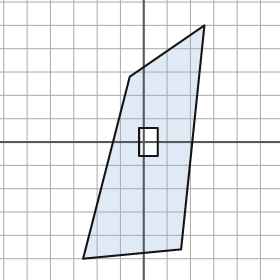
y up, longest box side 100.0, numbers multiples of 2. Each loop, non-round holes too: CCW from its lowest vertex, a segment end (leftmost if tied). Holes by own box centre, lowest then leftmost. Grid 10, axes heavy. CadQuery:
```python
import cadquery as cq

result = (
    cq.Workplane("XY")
    .moveTo(-26.0, -50.0)
    .lineTo(16.0, -46.0)
    .lineTo(26.0, 50.0)
    .lineTo(-6.0, 28.0)
    .close()
    .moveTo(-2.0, -6.0)
    .lineTo(6.0, -6.0)
    .lineTo(6.0, 6.0)
    .lineTo(-2.0, 6.0)
    .close()
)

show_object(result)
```